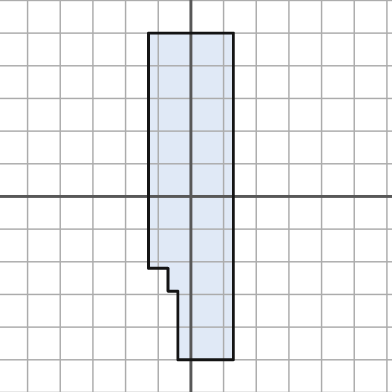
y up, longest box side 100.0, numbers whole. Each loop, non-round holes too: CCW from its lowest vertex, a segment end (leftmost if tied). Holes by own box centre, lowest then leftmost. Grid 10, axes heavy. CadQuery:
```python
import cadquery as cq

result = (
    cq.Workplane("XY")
    .moveTo(-4.0, -50.0)
    .lineTo(13.0, -50.0)
    .lineTo(13.0, 50.0)
    .lineTo(-13.0, 50.0)
    .lineTo(-13.0, -22.0)
    .lineTo(-7.0, -22.0)
    .lineTo(-7.0, -29.0)
    .lineTo(-4.0, -29.0)
    .close()
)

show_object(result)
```